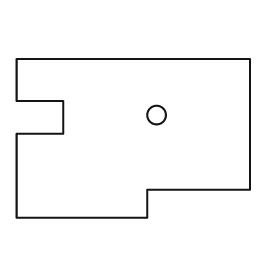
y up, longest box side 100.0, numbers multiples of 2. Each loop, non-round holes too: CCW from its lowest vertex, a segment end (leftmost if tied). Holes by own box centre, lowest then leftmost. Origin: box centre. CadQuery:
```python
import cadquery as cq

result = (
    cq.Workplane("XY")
    .moveTo(-50.0, -34.0)
    .lineTo(6.0, -34.0)
    .lineTo(6.0, -22.0)
    .lineTo(50.0, -22.0)
    .lineTo(50.0, 34.0)
    .lineTo(-50.0, 34.0)
    .lineTo(-50.0, 16.0)
    .lineTo(-30.0, 16.0)
    .lineTo(-30.0, 2.0)
    .lineTo(-50.0, 2.0)
    .close()
    .moveTo(10.0, 10.0)
    .circle(4.0)
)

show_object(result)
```